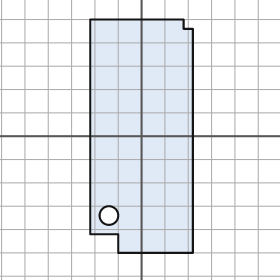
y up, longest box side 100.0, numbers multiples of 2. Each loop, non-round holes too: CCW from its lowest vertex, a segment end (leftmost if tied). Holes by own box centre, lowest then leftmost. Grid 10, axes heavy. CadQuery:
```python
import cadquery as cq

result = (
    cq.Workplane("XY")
    .moveTo(-10.0, -50.0)
    .lineTo(22.0, -50.0)
    .lineTo(22.0, 46.0)
    .lineTo(18.0, 46.0)
    .lineTo(18.0, 50.0)
    .lineTo(-22.0, 50.0)
    .lineTo(-22.0, -42.0)
    .lineTo(-10.0, -42.0)
    .close()
    .moveTo(-14.0, -34.0)
    .circle(4.0)
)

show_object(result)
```